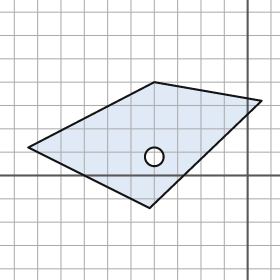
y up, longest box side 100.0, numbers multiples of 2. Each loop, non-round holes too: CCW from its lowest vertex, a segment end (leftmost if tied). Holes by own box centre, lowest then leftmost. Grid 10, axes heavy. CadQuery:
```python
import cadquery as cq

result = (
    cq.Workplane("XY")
    .moveTo(-42.0, -14.0)
    .lineTo(6.0, 32.0)
    .lineTo(-40.0, 40.0)
    .lineTo(-94.0, 12.0)
    .close()
    .moveTo(-40.0, 8.0)
    .circle(4.0)
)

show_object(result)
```